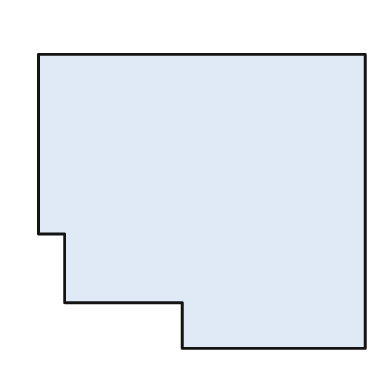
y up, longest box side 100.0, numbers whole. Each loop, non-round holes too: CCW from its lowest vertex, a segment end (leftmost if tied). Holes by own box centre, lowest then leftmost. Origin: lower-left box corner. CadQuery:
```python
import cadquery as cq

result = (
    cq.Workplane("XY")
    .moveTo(44.0, 0.0)
    .lineTo(100.0, 0.0)
    .lineTo(100.0, 90.0)
    .lineTo(0.0, 90.0)
    .lineTo(0.0, 35.0)
    .lineTo(8.0, 35.0)
    .lineTo(8.0, 14.0)
    .lineTo(44.0, 14.0)
    .close()
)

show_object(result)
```